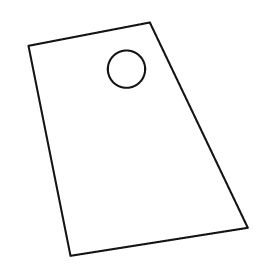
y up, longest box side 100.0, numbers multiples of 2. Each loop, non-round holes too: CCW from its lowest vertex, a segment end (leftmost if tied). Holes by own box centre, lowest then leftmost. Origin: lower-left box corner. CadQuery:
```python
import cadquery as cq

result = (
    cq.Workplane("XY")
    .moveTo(18.0, 0.0)
    .lineTo(94.0, 12.0)
    .lineTo(52.0, 100.0)
    .lineTo(0.0, 90.0)
    .close()
    .moveTo(42.0, 80.0)
    .circle(8.0)
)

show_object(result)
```